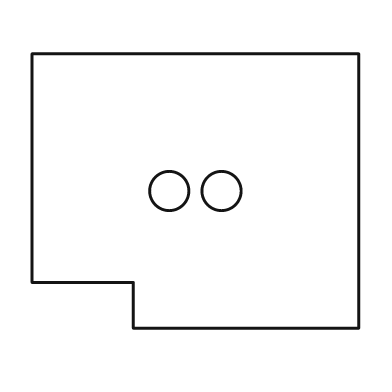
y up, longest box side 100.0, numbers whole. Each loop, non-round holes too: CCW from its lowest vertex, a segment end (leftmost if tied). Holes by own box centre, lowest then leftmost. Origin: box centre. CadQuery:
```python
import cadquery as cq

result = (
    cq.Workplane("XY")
    .moveTo(-19.0, -42.0)
    .lineTo(50.0, -42.0)
    .lineTo(50.0, 42.0)
    .lineTo(-50.0, 42.0)
    .lineTo(-50.0, -28.0)
    .lineTo(-19.0, -28.0)
    .close()
    .moveTo(-8.0, 0.0)
    .circle(6.0)
    .moveTo(8.0, 0.0)
    .circle(6.0)
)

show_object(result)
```